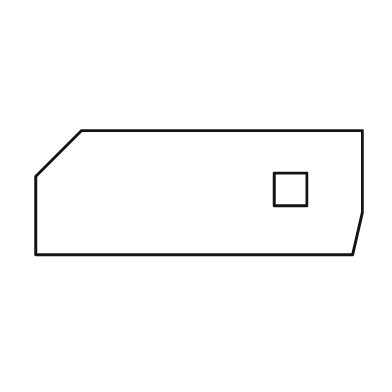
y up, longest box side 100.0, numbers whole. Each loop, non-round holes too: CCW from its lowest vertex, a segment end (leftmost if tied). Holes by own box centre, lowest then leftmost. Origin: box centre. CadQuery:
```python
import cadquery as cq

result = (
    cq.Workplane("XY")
    .moveTo(-50.0, -19.0)
    .lineTo(47.0, -19.0)
    .lineTo(50.0, -6.0)
    .lineTo(50.0, 19.0)
    .lineTo(-36.0, 19.0)
    .lineTo(-50.0, 5.0)
    .close()
    .moveTo(23.0, -4.0)
    .lineTo(33.0, -4.0)
    .lineTo(33.0, 6.0)
    .lineTo(23.0, 6.0)
    .close()
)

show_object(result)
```